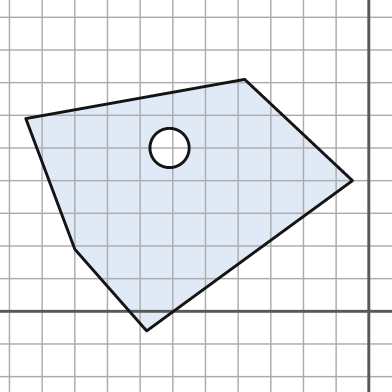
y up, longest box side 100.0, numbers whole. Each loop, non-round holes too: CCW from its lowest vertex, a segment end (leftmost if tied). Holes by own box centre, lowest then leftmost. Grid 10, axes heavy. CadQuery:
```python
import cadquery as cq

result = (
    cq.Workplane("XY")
    .moveTo(-68.0, -6.0)
    .lineTo(-5.0, 40.0)
    .lineTo(-38.0, 71.0)
    .lineTo(-105.0, 59.0)
    .lineTo(-90.0, 19.0)
    .close()
    .moveTo(-61.0, 50.0)
    .circle(6.0)
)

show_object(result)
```